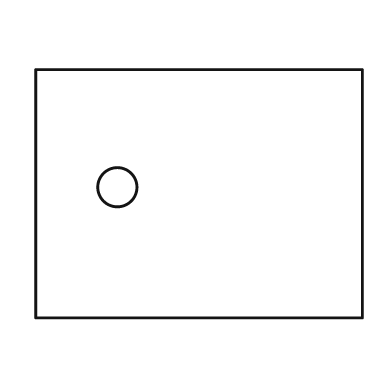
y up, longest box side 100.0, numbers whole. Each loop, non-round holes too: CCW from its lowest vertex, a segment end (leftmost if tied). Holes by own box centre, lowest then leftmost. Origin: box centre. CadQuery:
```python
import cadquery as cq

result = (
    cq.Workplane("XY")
    .moveTo(-50.0, -38.0)
    .lineTo(50.0, -38.0)
    .lineTo(50.0, 38.0)
    .lineTo(-50.0, 38.0)
    .close()
    .moveTo(-25.0, 2.0)
    .circle(6.0)
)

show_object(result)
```